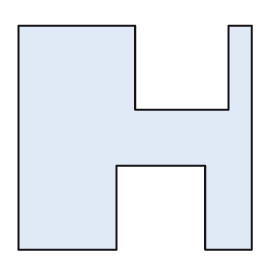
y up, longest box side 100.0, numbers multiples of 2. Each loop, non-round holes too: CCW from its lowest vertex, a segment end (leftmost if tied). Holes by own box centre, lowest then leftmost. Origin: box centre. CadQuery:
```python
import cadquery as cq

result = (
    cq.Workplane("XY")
    .moveTo(-50.0, -48.0)
    .lineTo(-8.0, -48.0)
    .lineTo(-8.0, -12.0)
    .lineTo(30.0, -12.0)
    .lineTo(30.0, -48.0)
    .lineTo(50.0, -48.0)
    .lineTo(50.0, 48.0)
    .lineTo(40.0, 48.0)
    .lineTo(40.0, 12.0)
    .lineTo(0.0, 12.0)
    .lineTo(0.0, 48.0)
    .lineTo(-50.0, 48.0)
    .close()
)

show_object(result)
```